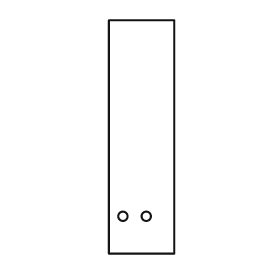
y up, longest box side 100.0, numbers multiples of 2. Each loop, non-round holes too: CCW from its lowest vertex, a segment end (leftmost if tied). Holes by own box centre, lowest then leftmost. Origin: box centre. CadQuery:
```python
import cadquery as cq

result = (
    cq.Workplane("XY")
    .moveTo(-14.0, -50.0)
    .lineTo(14.0, -50.0)
    .lineTo(14.0, 50.0)
    .lineTo(-14.0, 50.0)
    .close()
    .moveTo(-8.0, -34.0)
    .circle(2.0)
    .moveTo(2.0, -34.0)
    .circle(2.0)
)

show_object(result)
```